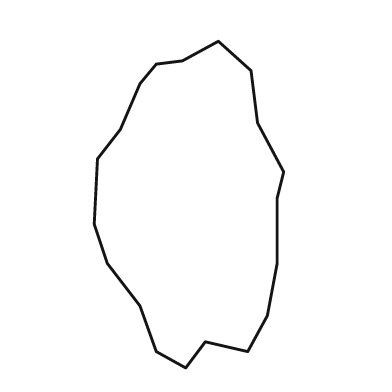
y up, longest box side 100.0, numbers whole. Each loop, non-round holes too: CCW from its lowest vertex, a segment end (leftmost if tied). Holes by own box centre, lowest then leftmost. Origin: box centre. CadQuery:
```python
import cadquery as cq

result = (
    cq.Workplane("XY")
    .moveTo(-1.0, -50.0)
    .lineTo(5.0, -42.0)
    .lineTo(18.0, -45.0)
    .lineTo(24.0, -34.0)
    .lineTo(27.0, -18.0)
    .lineTo(27.0, 2.0)
    .lineTo(29.0, 10.0)
    .lineTo(21.0, 25.0)
    .lineTo(19.0, 41.0)
    .lineTo(9.0, 50.0)
    .lineTo(-2.0, 44.0)
    .lineTo(-10.0, 43.0)
    .lineTo(-15.0, 37.0)
    .lineTo(-21.0, 23.0)
    .lineTo(-28.0, 14.0)
    .lineTo(-29.0, -6.0)
    .lineTo(-25.0, -18.0)
    .lineTo(-15.0, -31.0)
    .lineTo(-10.0, -45.0)
    .close()
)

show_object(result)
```